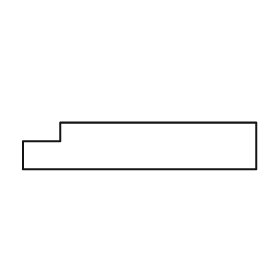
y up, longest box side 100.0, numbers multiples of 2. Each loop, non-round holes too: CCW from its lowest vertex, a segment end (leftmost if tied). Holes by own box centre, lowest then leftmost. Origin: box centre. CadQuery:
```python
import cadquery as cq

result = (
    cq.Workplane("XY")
    .moveTo(-50.0, -10.0)
    .lineTo(50.0, -10.0)
    .lineTo(50.0, 10.0)
    .lineTo(-34.0, 10.0)
    .lineTo(-34.0, 2.0)
    .lineTo(-50.0, 2.0)
    .close()
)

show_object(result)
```